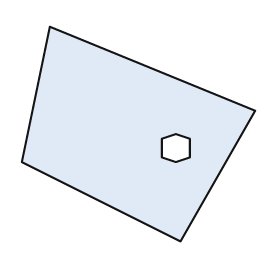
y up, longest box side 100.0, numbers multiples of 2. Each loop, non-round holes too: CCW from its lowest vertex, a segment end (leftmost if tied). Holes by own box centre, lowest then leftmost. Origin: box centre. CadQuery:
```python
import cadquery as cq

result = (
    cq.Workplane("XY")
    .moveTo(18.0, -46.0)
    .lineTo(50.0, 10.0)
    .lineTo(-38.0, 46.0)
    .lineTo(-50.0, -12.0)
    .close()
    .moveTo(16.0, -12.0)
    .lineTo(22.0, -10.0)
    .lineTo(22.0, -2.0)
    .lineTo(16.0, 0.0)
    .lineTo(10.0, -2.0)
    .lineTo(10.0, -10.0)
    .close()
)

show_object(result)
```